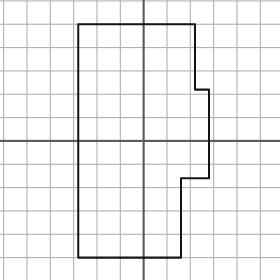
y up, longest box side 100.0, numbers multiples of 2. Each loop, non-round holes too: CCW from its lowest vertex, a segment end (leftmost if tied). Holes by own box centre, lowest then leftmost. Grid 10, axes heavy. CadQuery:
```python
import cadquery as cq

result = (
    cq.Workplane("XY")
    .moveTo(-28.0, -50.0)
    .lineTo(16.0, -50.0)
    .lineTo(16.0, -16.0)
    .lineTo(28.0, -16.0)
    .lineTo(28.0, 22.0)
    .lineTo(22.0, 22.0)
    .lineTo(22.0, 50.0)
    .lineTo(-28.0, 50.0)
    .close()
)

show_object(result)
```